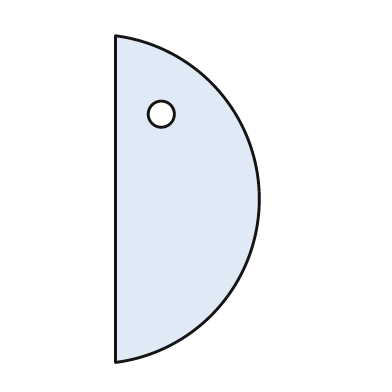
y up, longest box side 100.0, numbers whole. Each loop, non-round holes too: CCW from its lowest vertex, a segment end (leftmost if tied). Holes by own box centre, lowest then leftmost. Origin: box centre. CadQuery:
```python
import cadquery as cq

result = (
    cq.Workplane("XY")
    .moveTo(-22.0, -50.0)
    .threePointArc((22.0, 0.0), (-22.0, 50.0))
    .close()
    .moveTo(-8.0, 26.0)
    .circle(4.0)
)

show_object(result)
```